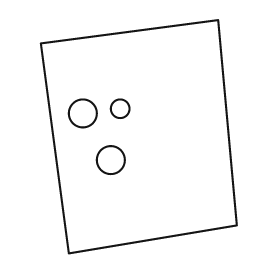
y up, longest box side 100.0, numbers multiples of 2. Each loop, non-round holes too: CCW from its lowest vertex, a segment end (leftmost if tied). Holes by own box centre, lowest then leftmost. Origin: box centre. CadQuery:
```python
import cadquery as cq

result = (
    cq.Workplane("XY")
    .moveTo(-30.0, -50.0)
    .lineTo(42.0, -38.0)
    .lineTo(34.0, 50.0)
    .lineTo(-42.0, 40.0)
    .close()
    .moveTo(-12.0, -10.0)
    .circle(6.0)
    .moveTo(-24.0, 10.0)
    .circle(6.0)
    .moveTo(-8.0, 12.0)
    .circle(4.0)
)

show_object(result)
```